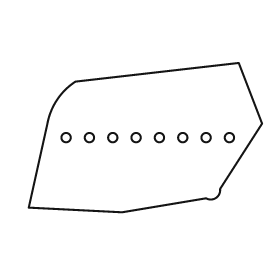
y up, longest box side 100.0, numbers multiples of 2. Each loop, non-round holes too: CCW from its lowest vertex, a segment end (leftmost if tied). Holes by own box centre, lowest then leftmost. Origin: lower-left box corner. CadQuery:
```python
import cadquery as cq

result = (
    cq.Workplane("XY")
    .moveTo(40.0, 0.0)
    .lineTo(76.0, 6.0)
    .threePointArc((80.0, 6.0), (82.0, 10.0))
    .lineTo(100.0, 38.0)
    .lineTo(90.0, 64.0)
    .lineTo(20.0, 56.0)
    .threePointArc((12.0, 48.0), (8.0, 38.0))
    .lineTo(0.0, 2.0)
    .close()
    .moveTo(16.0, 32.0)
    .circle(2.0)
    .moveTo(26.0, 32.0)
    .circle(2.0)
    .moveTo(36.0, 32.0)
    .circle(2.0)
    .moveTo(46.0, 32.0)
    .circle(2.0)
    .moveTo(56.0, 32.0)
    .circle(2.0)
    .moveTo(66.0, 32.0)
    .circle(2.0)
    .moveTo(76.0, 32.0)
    .circle(2.0)
    .moveTo(86.0, 32.0)
    .circle(2.0)
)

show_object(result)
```